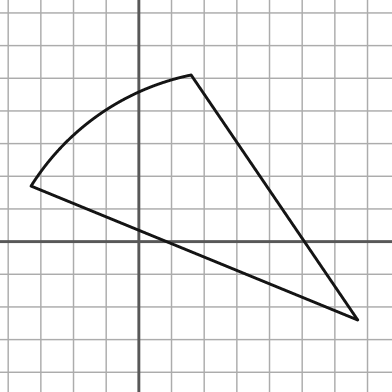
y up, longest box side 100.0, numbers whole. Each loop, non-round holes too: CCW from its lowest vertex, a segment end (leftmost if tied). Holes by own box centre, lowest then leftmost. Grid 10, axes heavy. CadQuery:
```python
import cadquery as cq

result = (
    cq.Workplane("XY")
    .moveTo(67.0, -24.0)
    .lineTo(16.0, 51.0)
    .threePointArc((-12.0, 39.0), (-33.0, 17.0))
    .close()
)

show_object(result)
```